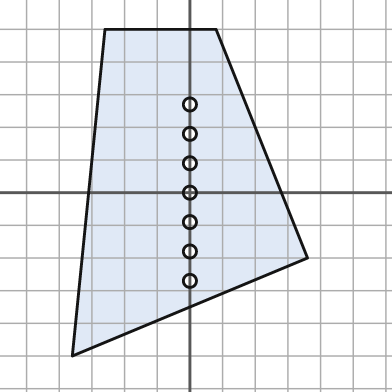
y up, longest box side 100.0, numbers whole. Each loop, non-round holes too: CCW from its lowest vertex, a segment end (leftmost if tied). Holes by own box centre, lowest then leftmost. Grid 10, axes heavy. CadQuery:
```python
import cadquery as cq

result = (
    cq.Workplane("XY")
    .moveTo(-36.0, -50.0)
    .lineTo(36.0, -20.0)
    .lineTo(8.0, 50.0)
    .lineTo(-26.0, 50.0)
    .close()
    .moveTo(0.0, -27.0)
    .circle(2.0)
    .moveTo(0.0, -18.0)
    .circle(2.0)
    .moveTo(0.0, -9.0)
    .circle(2.0)
    .moveTo(0.0, 0.0)
    .circle(2.0)
    .moveTo(0.0, 9.0)
    .circle(2.0)
    .moveTo(0.0, 18.0)
    .circle(2.0)
    .moveTo(0.0, 27.0)
    .circle(2.0)
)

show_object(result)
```